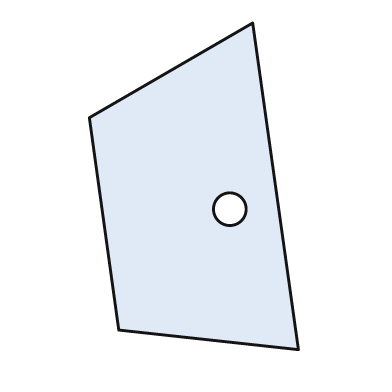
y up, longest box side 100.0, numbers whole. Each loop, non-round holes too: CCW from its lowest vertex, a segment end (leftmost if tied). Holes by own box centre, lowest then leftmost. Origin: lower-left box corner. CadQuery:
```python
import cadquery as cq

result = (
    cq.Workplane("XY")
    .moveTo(64.0, 0.0)
    .lineTo(50.0, 100.0)
    .lineTo(0.0, 71.0)
    .lineTo(9.0, 6.0)
    .close()
    .moveTo(43.0, 43.0)
    .circle(5.0)
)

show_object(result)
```